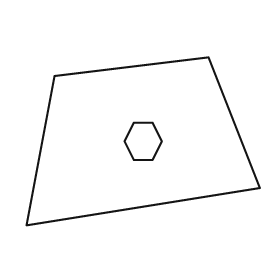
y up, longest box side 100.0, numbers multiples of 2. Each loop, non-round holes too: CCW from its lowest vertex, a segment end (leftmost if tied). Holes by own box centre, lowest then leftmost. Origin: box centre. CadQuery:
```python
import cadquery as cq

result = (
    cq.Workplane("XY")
    .moveTo(-50.0, -36.0)
    .lineTo(50.0, -20.0)
    .lineTo(28.0, 36.0)
    .lineTo(-38.0, 28.0)
    .close()
    .moveTo(-4.0, -8.0)
    .lineTo(4.0, -8.0)
    .lineTo(8.0, 0.0)
    .lineTo(4.0, 8.0)
    .lineTo(-4.0, 8.0)
    .lineTo(-8.0, 0.0)
    .close()
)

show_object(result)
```